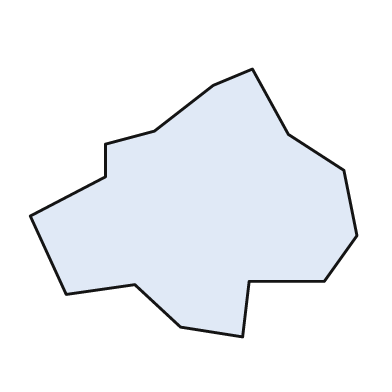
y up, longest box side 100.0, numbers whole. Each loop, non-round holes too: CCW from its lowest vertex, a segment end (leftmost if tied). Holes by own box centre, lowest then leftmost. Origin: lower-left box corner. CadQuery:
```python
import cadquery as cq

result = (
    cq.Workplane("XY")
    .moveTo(65.0, 0.0)
    .lineTo(67.0, 17.0)
    .lineTo(90.0, 17.0)
    .lineTo(100.0, 31.0)
    .lineTo(96.0, 51.0)
    .lineTo(79.0, 62.0)
    .lineTo(68.0, 82.0)
    .lineTo(56.0, 77.0)
    .lineTo(38.0, 63.0)
    .lineTo(23.0, 59.0)
    .lineTo(23.0, 49.0)
    .lineTo(0.0, 37.0)
    .lineTo(11.0, 13.0)
    .lineTo(32.0, 16.0)
    .lineTo(46.0, 3.0)
    .close()
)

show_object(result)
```